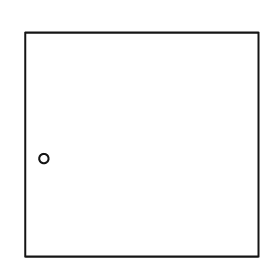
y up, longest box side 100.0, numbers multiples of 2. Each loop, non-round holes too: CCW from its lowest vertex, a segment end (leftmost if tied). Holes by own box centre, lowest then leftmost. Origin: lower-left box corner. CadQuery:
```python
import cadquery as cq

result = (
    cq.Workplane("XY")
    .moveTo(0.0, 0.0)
    .lineTo(100.0, 0.0)
    .lineTo(100.0, 96.0)
    .lineTo(0.0, 96.0)
    .close()
    .moveTo(8.0, 42.0)
    .circle(2.0)
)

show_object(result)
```